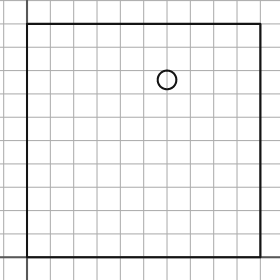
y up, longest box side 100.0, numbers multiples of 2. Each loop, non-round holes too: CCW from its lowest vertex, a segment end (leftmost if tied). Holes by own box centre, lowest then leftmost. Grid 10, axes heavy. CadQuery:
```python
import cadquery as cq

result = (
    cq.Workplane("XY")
    .moveTo(0.0, 0.0)
    .lineTo(100.0, 0.0)
    .lineTo(100.0, 100.0)
    .lineTo(0.0, 100.0)
    .close()
    .moveTo(60.0, 76.0)
    .circle(4.0)
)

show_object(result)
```